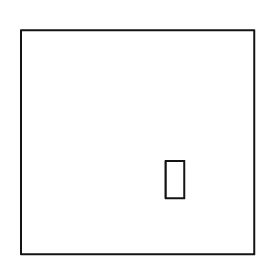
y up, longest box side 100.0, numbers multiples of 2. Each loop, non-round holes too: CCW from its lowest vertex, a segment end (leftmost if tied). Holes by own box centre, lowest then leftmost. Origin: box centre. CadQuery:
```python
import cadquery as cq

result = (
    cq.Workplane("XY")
    .moveTo(-50.0, -48.0)
    .lineTo(50.0, -48.0)
    .lineTo(50.0, 48.0)
    .lineTo(-50.0, 48.0)
    .close()
    .moveTo(12.0, -24.0)
    .lineTo(20.0, -24.0)
    .lineTo(20.0, -8.0)
    .lineTo(12.0, -8.0)
    .close()
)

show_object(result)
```